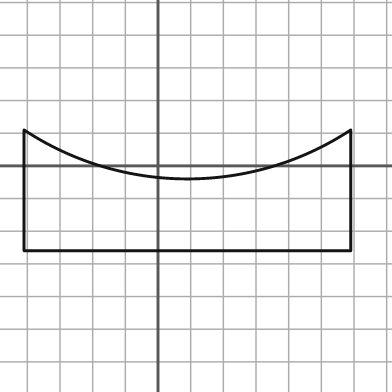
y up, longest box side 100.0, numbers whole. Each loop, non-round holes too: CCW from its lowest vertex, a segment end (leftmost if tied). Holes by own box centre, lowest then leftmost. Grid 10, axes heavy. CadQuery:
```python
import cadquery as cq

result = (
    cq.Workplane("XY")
    .moveTo(-41.0, -26.0)
    .lineTo(59.0, -26.0)
    .lineTo(59.0, 11.0)
    .threePointArc((9.0, -4.0), (-41.0, 11.0))
    .close()
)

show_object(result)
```